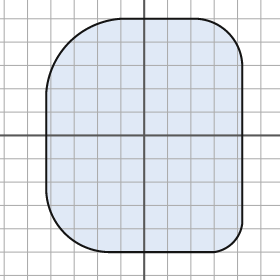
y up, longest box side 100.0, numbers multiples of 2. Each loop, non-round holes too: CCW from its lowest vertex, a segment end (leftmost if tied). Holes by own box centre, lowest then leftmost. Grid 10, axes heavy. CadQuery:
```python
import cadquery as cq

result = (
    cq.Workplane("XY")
    .moveTo(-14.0, -50.0)
    .lineTo(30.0, -50.0)
    .threePointArc((38.0, -46.0), (42.0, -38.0))
    .lineTo(42.0, 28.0)
    .threePointArc((36.0, 44.0), (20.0, 50.0))
    .lineTo(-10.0, 50.0)
    .threePointArc((-32.0, 40.0), (-42.0, 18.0))
    .lineTo(-42.0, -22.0)
    .threePointArc((-34.0, -42.0), (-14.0, -50.0))
    .close()
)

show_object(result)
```